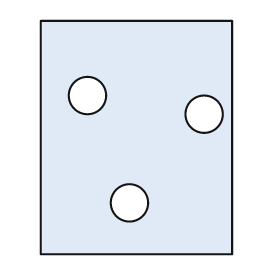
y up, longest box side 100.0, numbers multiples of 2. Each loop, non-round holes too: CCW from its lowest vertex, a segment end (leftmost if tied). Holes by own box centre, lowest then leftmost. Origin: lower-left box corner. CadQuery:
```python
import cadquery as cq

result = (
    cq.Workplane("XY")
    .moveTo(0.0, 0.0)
    .lineTo(82.0, 0.0)
    .lineTo(82.0, 100.0)
    .lineTo(0.0, 100.0)
    .close()
    .moveTo(38.0, 22.0)
    .circle(8.0)
    .moveTo(70.0, 60.0)
    .circle(8.0)
    .moveTo(20.0, 68.0)
    .circle(8.0)
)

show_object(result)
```